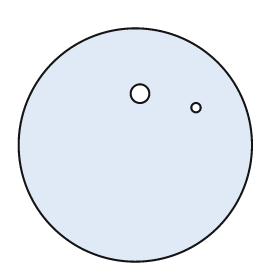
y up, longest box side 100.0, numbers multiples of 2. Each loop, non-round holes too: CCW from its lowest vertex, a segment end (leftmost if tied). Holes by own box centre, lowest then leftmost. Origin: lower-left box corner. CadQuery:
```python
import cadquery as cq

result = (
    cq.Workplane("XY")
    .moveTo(50.0, 50.0)
    .circle(50.0)
    .moveTo(76.0, 66.0)
    .circle(2.0)
    .moveTo(52.0, 72.0)
    .circle(4.0)
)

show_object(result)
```